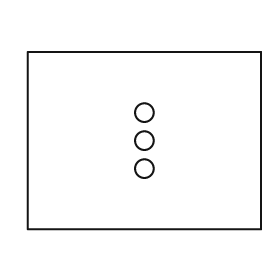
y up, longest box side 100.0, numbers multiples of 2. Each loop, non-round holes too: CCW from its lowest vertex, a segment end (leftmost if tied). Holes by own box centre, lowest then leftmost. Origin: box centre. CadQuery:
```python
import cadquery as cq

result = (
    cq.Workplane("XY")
    .moveTo(-50.0, -38.0)
    .lineTo(50.0, -38.0)
    .lineTo(50.0, 38.0)
    .lineTo(-50.0, 38.0)
    .close()
    .moveTo(0.0, -12.0)
    .circle(4.0)
    .moveTo(0.0, 0.0)
    .circle(4.0)
    .moveTo(0.0, 12.0)
    .circle(4.0)
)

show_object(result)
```